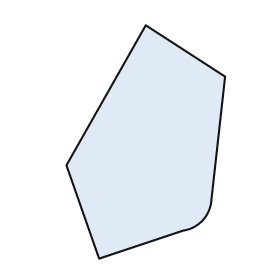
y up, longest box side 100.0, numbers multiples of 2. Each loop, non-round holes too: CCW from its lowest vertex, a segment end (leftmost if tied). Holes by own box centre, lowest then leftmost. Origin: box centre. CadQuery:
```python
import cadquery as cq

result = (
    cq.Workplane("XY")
    .moveTo(-20.0, -50.0)
    .lineTo(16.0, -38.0)
    .threePointArc((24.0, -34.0), (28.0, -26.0))
    .lineTo(34.0, 28.0)
    .lineTo(0.0, 50.0)
    .lineTo(-34.0, -10.0)
    .close()
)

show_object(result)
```